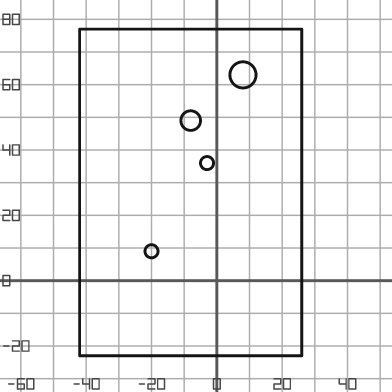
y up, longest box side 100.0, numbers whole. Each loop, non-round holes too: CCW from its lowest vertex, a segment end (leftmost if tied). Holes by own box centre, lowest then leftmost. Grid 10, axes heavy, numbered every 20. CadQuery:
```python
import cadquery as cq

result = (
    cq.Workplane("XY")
    .moveTo(-42.0, -23.0)
    .lineTo(26.0, -23.0)
    .lineTo(26.0, 77.0)
    .lineTo(-42.0, 77.0)
    .close()
    .moveTo(-20.0, 9.0)
    .circle(2.0)
    .moveTo(-3.0, 36.0)
    .circle(2.0)
    .moveTo(-8.0, 49.0)
    .circle(3.0)
    .moveTo(8.0, 63.0)
    .circle(4.0)
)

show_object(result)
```